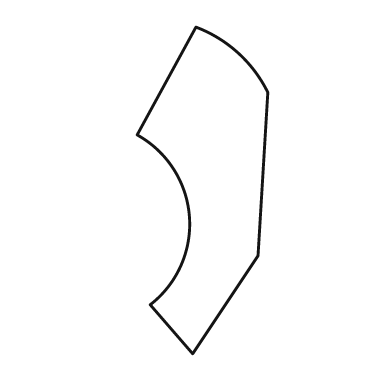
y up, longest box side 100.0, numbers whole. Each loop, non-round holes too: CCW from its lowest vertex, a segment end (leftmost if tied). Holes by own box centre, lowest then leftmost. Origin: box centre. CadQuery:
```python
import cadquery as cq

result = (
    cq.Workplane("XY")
    .moveTo(-3.0, -50.0)
    .lineTo(17.0, -20.0)
    .lineTo(20.0, 30.0)
    .threePointArc((11.0, 42.0), (-2.0, 50.0))
    .lineTo(-20.0, 17.0)
    .threePointArc((-4.0, -8.0), (-16.0, -35.0))
    .close()
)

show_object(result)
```